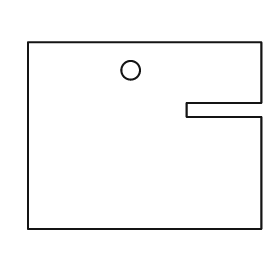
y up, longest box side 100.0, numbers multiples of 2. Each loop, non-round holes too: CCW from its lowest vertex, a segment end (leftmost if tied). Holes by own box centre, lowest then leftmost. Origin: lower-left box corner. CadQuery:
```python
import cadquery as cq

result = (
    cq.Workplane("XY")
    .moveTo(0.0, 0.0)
    .lineTo(100.0, 0.0)
    .lineTo(100.0, 48.0)
    .lineTo(68.0, 48.0)
    .lineTo(68.0, 54.0)
    .lineTo(100.0, 54.0)
    .lineTo(100.0, 80.0)
    .lineTo(0.0, 80.0)
    .close()
    .moveTo(44.0, 68.0)
    .circle(4.0)
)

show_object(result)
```